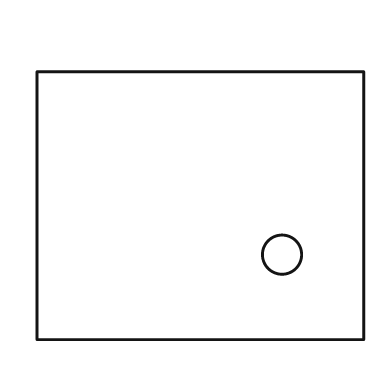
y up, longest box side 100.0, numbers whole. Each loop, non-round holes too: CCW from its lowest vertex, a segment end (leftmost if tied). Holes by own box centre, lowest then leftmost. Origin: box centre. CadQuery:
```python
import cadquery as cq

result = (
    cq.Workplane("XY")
    .moveTo(-50.0, -41.0)
    .lineTo(50.0, -41.0)
    .lineTo(50.0, 41.0)
    .lineTo(-50.0, 41.0)
    .close()
    .moveTo(25.0, -15.0)
    .circle(6.0)
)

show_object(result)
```